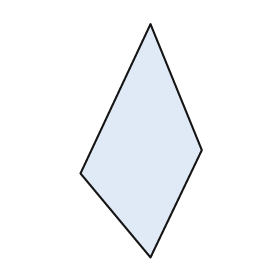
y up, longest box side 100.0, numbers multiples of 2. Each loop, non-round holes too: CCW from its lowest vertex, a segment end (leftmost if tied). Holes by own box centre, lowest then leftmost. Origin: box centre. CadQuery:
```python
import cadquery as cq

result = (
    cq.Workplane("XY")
    .moveTo(4.0, -50.0)
    .lineTo(26.0, -4.0)
    .lineTo(4.0, 50.0)
    .lineTo(-26.0, -14.0)
    .close()
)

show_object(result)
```